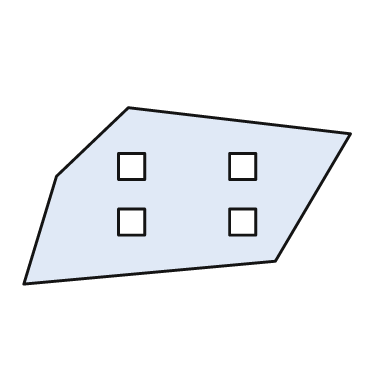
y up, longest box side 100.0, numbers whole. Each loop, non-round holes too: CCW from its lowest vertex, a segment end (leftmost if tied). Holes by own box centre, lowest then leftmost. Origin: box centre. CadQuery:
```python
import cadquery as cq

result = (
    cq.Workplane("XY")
    .moveTo(-50.0, -27.0)
    .lineTo(27.0, -20.0)
    .lineTo(50.0, 19.0)
    .lineTo(-18.0, 27.0)
    .lineTo(-40.0, 6.0)
    .close()
    .moveTo(-21.0, -12.0)
    .lineTo(-13.0, -12.0)
    .lineTo(-13.0, -4.0)
    .lineTo(-21.0, -4.0)
    .close()
    .moveTo(13.0, -12.0)
    .lineTo(21.0, -12.0)
    .lineTo(21.0, -4.0)
    .lineTo(13.0, -4.0)
    .close()
    .moveTo(-21.0, 5.0)
    .lineTo(-13.0, 5.0)
    .lineTo(-13.0, 13.0)
    .lineTo(-21.0, 13.0)
    .close()
    .moveTo(13.0, 5.0)
    .lineTo(21.0, 5.0)
    .lineTo(21.0, 13.0)
    .lineTo(13.0, 13.0)
    .close()
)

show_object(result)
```